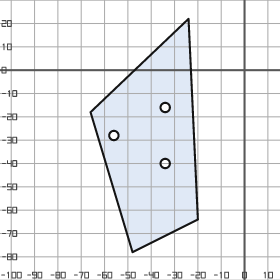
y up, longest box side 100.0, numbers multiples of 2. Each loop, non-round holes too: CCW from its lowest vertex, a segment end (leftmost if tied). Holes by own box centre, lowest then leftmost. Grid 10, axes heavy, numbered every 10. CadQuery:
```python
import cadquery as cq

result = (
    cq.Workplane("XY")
    .moveTo(-48.0, -78.0)
    .lineTo(-20.0, -64.0)
    .lineTo(-24.0, 22.0)
    .lineTo(-66.0, -18.0)
    .close()
    .moveTo(-34.0, -40.0)
    .circle(2.0)
    .moveTo(-56.0, -28.0)
    .circle(2.0)
    .moveTo(-34.0, -16.0)
    .circle(2.0)
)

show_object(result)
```